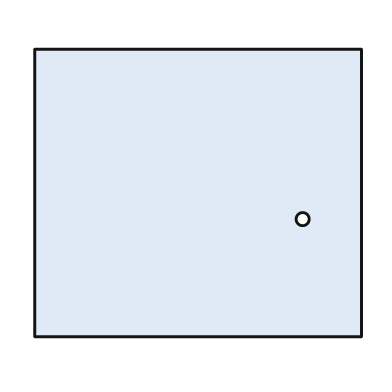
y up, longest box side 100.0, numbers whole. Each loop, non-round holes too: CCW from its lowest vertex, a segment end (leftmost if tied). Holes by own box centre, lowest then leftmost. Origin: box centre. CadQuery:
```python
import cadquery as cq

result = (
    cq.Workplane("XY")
    .moveTo(-50.0, -44.0)
    .lineTo(50.0, -44.0)
    .lineTo(50.0, 44.0)
    .lineTo(-50.0, 44.0)
    .close()
    .moveTo(32.0, -8.0)
    .circle(2.0)
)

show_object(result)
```